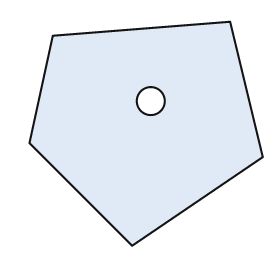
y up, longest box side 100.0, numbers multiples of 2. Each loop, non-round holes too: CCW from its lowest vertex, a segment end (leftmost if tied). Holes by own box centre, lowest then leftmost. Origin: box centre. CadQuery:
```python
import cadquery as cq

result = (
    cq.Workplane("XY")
    .moveTo(-6.0, -48.0)
    .lineTo(50.0, -10.0)
    .lineTo(36.0, 48.0)
    .lineTo(-40.0, 42.0)
    .lineTo(-50.0, -4.0)
    .close()
    .moveTo(2.0, 14.0)
    .circle(6.0)
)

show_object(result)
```